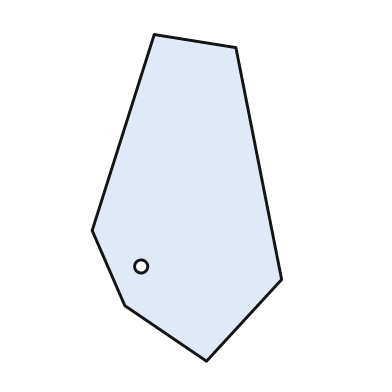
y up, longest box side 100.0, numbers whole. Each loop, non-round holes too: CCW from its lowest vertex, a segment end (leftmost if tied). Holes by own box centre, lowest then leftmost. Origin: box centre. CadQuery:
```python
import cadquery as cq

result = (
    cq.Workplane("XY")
    .moveTo(6.0, -50.0)
    .lineTo(29.0, -25.0)
    .lineTo(15.0, 46.0)
    .lineTo(-10.0, 50.0)
    .lineTo(-29.0, -10.0)
    .lineTo(-19.0, -33.0)
    .close()
    .moveTo(-14.0, -21.0)
    .circle(2.0)
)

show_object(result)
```